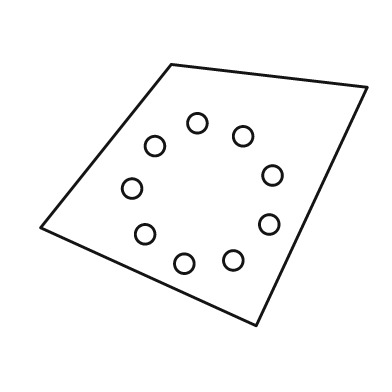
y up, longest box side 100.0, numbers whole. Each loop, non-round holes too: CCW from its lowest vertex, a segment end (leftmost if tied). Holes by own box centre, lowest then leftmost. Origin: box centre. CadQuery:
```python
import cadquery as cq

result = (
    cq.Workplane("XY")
    .moveTo(16.0, -40.0)
    .lineTo(50.0, 33.0)
    .lineTo(-10.0, 40.0)
    .lineTo(-50.0, -10.0)
    .close()
    .moveTo(-6.0, -21.0)
    .circle(3.0)
    .moveTo(9.0, -20.0)
    .circle(3.0)
    .moveTo(-18.0, -12.0)
    .circle(3.0)
    .moveTo(20.0, -9.0)
    .circle(3.0)
    .moveTo(-22.0, 2.0)
    .circle(3.0)
    .moveTo(21.0, 6.0)
    .circle(3.0)
    .moveTo(-15.0, 15.0)
    .circle(3.0)
    .moveTo(12.0, 18.0)
    .circle(3.0)
    .moveTo(-2.0, 22.0)
    .circle(3.0)
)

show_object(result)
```